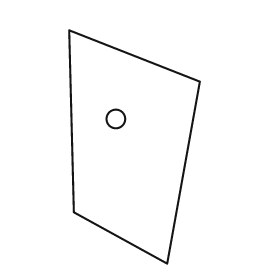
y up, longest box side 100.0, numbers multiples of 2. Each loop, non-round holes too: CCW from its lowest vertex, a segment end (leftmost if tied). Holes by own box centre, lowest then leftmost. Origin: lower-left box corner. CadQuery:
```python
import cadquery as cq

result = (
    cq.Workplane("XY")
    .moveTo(42.0, 0.0)
    .lineTo(56.0, 78.0)
    .lineTo(0.0, 100.0)
    .lineTo(2.0, 22.0)
    .close()
    .moveTo(20.0, 62.0)
    .circle(4.0)
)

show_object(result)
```